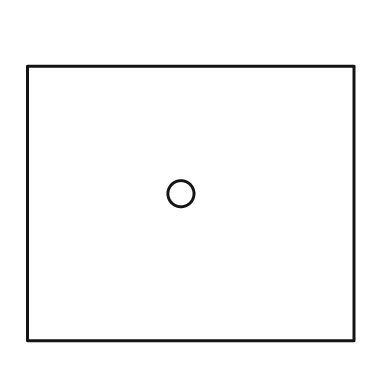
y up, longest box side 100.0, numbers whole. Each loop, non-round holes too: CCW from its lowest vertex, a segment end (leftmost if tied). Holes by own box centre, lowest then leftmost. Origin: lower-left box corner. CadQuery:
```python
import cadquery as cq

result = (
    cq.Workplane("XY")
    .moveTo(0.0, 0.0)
    .lineTo(100.0, 0.0)
    .lineTo(100.0, 84.0)
    .lineTo(0.0, 84.0)
    .close()
    .moveTo(47.0, 45.0)
    .circle(4.0)
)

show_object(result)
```